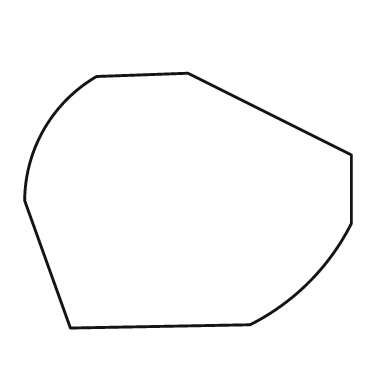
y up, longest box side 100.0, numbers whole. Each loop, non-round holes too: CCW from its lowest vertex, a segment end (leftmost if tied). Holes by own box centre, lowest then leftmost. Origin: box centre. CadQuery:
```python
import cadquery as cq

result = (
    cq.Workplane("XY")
    .moveTo(-36.0, -39.0)
    .lineTo(19.0, -38.0)
    .threePointArc((37.0, -25.0), (50.0, -7.0))
    .lineTo(50.0, 14.0)
    .lineTo(0.0, 39.0)
    .lineTo(-28.0, 38.0)
    .threePointArc((-44.0, 22.0), (-50.0, 0.0))
    .close()
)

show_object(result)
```